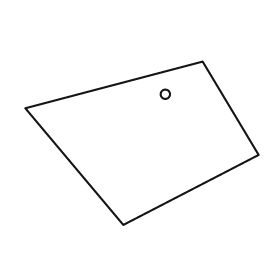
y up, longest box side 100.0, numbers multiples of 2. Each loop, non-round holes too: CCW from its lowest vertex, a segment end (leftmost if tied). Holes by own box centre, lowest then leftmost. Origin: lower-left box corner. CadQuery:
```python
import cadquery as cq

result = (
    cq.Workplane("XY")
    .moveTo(42.0, 0.0)
    .lineTo(100.0, 30.0)
    .lineTo(76.0, 70.0)
    .lineTo(0.0, 50.0)
    .close()
    .moveTo(60.0, 56.0)
    .circle(2.0)
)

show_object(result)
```